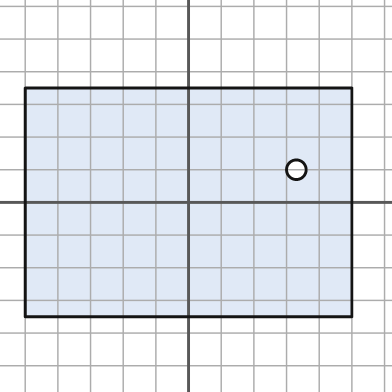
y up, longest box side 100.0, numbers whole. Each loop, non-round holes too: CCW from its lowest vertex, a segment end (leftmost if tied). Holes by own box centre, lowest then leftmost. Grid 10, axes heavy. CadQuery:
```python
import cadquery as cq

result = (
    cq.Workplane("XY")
    .moveTo(-50.0, -35.0)
    .lineTo(50.0, -35.0)
    .lineTo(50.0, 35.0)
    .lineTo(-50.0, 35.0)
    .close()
    .moveTo(33.0, 10.0)
    .circle(3.0)
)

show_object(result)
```